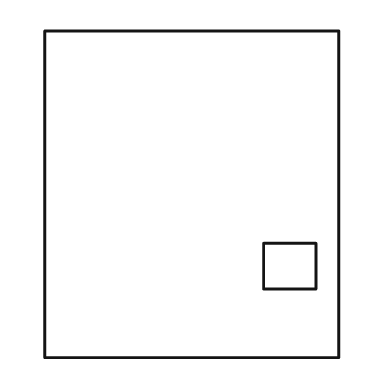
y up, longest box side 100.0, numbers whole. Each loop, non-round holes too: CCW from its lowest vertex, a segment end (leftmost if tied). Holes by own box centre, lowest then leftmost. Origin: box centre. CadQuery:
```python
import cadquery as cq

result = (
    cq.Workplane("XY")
    .moveTo(-45.0, -50.0)
    .lineTo(45.0, -50.0)
    .lineTo(45.0, 50.0)
    .lineTo(-45.0, 50.0)
    .close()
    .moveTo(22.0, -29.0)
    .lineTo(38.0, -29.0)
    .lineTo(38.0, -15.0)
    .lineTo(22.0, -15.0)
    .close()
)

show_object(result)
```